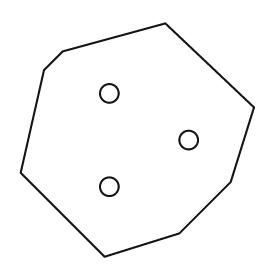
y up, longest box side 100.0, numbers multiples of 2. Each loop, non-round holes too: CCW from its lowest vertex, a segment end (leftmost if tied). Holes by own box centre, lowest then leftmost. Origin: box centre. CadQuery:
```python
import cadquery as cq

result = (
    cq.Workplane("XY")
    .moveTo(-14.0, -50.0)
    .lineTo(18.0, -40.0)
    .lineTo(40.0, -18.0)
    .lineTo(50.0, 14.0)
    .lineTo(12.0, 50.0)
    .lineTo(-32.0, 38.0)
    .lineTo(-40.0, 30.0)
    .lineTo(-50.0, -14.0)
    .close()
    .moveTo(-12.0, -20.0)
    .circle(4.0)
    .moveTo(22.0, 0.0)
    .circle(4.0)
    .moveTo(-12.0, 20.0)
    .circle(4.0)
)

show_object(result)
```